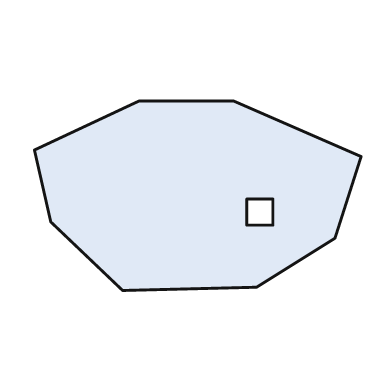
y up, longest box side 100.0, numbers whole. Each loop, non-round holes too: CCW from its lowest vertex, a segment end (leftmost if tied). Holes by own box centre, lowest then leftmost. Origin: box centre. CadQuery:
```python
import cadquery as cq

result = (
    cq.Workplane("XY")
    .moveTo(-23.0, -29.0)
    .lineTo(18.0, -28.0)
    .lineTo(42.0, -13.0)
    .lineTo(50.0, 12.0)
    .lineTo(11.0, 29.0)
    .lineTo(-18.0, 29.0)
    .lineTo(-50.0, 14.0)
    .lineTo(-45.0, -8.0)
    .close()
    .moveTo(15.0, -9.0)
    .lineTo(23.0, -9.0)
    .lineTo(23.0, -1.0)
    .lineTo(15.0, -1.0)
    .close()
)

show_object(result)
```